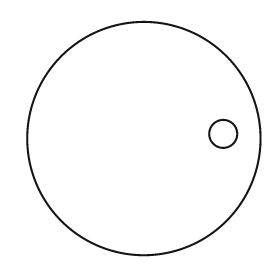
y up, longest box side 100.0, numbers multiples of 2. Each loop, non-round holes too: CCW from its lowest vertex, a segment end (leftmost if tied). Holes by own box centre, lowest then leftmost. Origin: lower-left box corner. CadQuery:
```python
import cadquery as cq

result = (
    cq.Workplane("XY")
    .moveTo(50.0, 50.0)
    .circle(50.0)
    .moveTo(84.0, 52.0)
    .circle(6.0)
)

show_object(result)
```